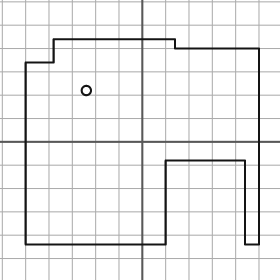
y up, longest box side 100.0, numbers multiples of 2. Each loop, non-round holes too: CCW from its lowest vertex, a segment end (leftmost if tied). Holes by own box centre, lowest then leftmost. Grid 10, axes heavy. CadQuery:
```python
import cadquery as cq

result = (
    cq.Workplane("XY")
    .moveTo(-50.0, -44.0)
    .lineTo(10.0, -44.0)
    .lineTo(10.0, -8.0)
    .lineTo(44.0, -8.0)
    .lineTo(44.0, -44.0)
    .lineTo(50.0, -44.0)
    .lineTo(50.0, 40.0)
    .lineTo(14.0, 40.0)
    .lineTo(14.0, 44.0)
    .lineTo(-38.0, 44.0)
    .lineTo(-38.0, 34.0)
    .lineTo(-50.0, 34.0)
    .close()
    .moveTo(-24.0, 22.0)
    .circle(2.0)
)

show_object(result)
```